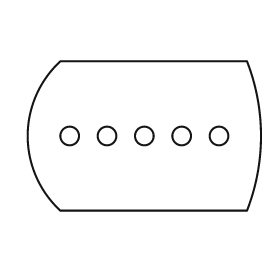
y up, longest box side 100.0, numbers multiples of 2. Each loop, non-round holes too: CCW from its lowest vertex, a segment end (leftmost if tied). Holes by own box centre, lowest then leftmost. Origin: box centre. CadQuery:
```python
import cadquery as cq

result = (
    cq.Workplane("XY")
    .moveTo(-36.0, -32.0)
    .lineTo(44.0, -32.0)
    .threePointArc((50.0, 0.0), (44.0, 32.0))
    .lineTo(-36.0, 32.0)
    .threePointArc((-50.0, 0.0), (-36.0, -32.0))
    .close()
    .moveTo(-32.0, 0.0)
    .circle(4.0)
    .moveTo(-16.0, 0.0)
    .circle(4.0)
    .moveTo(0.0, 0.0)
    .circle(4.0)
    .moveTo(16.0, 0.0)
    .circle(4.0)
    .moveTo(32.0, 0.0)
    .circle(4.0)
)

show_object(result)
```